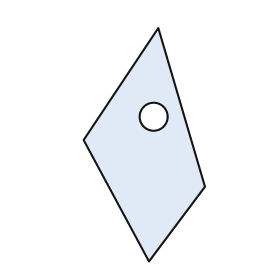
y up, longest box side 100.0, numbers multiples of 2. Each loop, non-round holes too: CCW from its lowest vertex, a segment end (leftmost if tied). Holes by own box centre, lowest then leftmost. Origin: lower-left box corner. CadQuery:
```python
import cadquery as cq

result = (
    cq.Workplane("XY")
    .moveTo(28.0, 0.0)
    .lineTo(52.0, 32.0)
    .lineTo(32.0, 100.0)
    .lineTo(0.0, 52.0)
    .close()
    .moveTo(30.0, 62.0)
    .circle(6.0)
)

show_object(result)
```